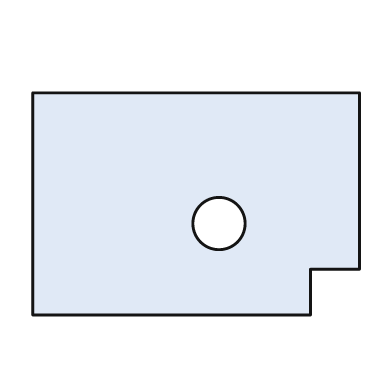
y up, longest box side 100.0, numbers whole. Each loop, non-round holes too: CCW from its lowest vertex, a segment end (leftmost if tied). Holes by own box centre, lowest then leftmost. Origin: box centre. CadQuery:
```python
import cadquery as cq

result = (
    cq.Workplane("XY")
    .moveTo(-50.0, -34.0)
    .lineTo(35.0, -34.0)
    .lineTo(35.0, -20.0)
    .lineTo(50.0, -20.0)
    .lineTo(50.0, 34.0)
    .lineTo(-50.0, 34.0)
    .close()
    .moveTo(7.0, -6.0)
    .circle(8.0)
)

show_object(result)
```